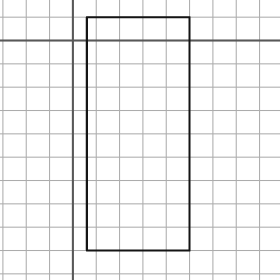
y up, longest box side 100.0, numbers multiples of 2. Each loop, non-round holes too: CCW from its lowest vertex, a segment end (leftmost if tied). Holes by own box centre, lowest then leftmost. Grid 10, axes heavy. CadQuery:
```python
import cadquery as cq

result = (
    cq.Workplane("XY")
    .moveTo(6.0, -90.0)
    .lineTo(50.0, -90.0)
    .lineTo(50.0, 10.0)
    .lineTo(6.0, 10.0)
    .close()
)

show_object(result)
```